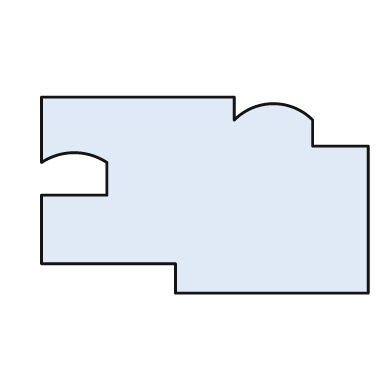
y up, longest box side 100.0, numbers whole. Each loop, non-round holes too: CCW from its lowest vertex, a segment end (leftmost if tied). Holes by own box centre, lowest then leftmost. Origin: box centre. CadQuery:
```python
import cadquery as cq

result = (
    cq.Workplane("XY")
    .moveTo(-9.0, -30.0)
    .lineTo(50.0, -30.0)
    .lineTo(50.0, 15.0)
    .lineTo(33.0, 15.0)
    .lineTo(33.0, 23.0)
    .threePointArc((21.0, 28.0), (9.0, 23.0))
    .lineTo(9.0, 30.0)
    .lineTo(-50.0, 30.0)
    .lineTo(-50.0, 10.0)
    .threePointArc((-40.0, 13.0), (-30.0, 10.0))
    .lineTo(-30.0, 0.0)
    .lineTo(-50.0, 0.0)
    .lineTo(-50.0, -21.0)
    .lineTo(-9.0, -21.0)
    .close()
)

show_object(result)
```